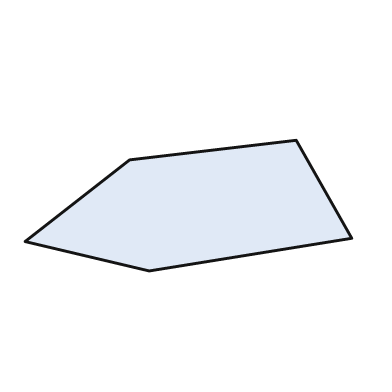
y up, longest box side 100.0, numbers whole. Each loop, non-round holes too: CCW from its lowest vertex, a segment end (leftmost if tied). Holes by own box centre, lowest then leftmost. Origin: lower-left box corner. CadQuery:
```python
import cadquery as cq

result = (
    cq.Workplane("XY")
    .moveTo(38.0, 0.0)
    .lineTo(100.0, 10.0)
    .lineTo(83.0, 40.0)
    .lineTo(32.0, 34.0)
    .lineTo(0.0, 9.0)
    .close()
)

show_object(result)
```